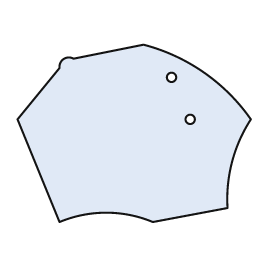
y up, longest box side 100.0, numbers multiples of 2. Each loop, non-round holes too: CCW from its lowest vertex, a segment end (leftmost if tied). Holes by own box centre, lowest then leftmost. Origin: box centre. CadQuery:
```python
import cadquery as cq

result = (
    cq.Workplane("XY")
    .moveTo(-32.0, -38.0)
    .threePointArc((-12.0, -34.0), (8.0, -38.0))
    .lineTo(40.0, -32.0)
    .threePointArc((42.0, -12.0), (50.0, 6.0))
    .threePointArc((30.0, 26.0), (4.0, 38.0))
    .lineTo(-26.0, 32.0)
    .threePointArc((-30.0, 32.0), (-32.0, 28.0))
    .lineTo(-50.0, 6.0)
    .close()
    .moveTo(24.0, 6.0)
    .circle(2.0)
    .moveTo(16.0, 24.0)
    .circle(2.0)
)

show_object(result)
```